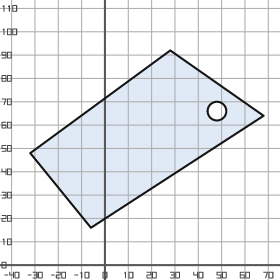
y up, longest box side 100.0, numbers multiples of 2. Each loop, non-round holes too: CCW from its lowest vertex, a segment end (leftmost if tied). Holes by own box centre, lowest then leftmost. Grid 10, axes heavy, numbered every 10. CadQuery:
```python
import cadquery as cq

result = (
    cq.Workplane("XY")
    .moveTo(-6.0, 16.0)
    .lineTo(68.0, 64.0)
    .lineTo(28.0, 92.0)
    .lineTo(-32.0, 48.0)
    .close()
    .moveTo(48.0, 66.0)
    .circle(4.0)
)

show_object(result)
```